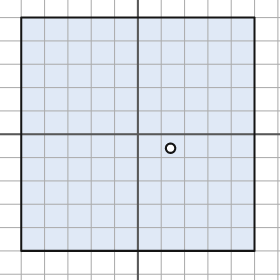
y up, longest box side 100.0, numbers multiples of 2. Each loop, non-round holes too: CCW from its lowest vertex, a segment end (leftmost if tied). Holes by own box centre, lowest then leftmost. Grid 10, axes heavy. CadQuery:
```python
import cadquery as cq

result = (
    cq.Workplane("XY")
    .moveTo(-50.0, -50.0)
    .lineTo(50.0, -50.0)
    .lineTo(50.0, 50.0)
    .lineTo(-50.0, 50.0)
    .close()
    .moveTo(14.0, -6.0)
    .circle(2.0)
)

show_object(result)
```